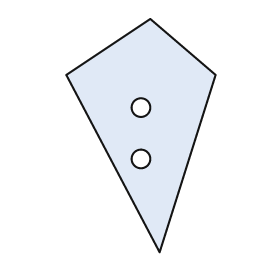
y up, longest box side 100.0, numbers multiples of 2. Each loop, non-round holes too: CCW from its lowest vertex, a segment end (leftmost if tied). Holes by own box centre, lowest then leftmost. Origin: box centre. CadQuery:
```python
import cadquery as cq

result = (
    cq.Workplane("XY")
    .moveTo(8.0, -50.0)
    .lineTo(32.0, 26.0)
    .lineTo(4.0, 50.0)
    .lineTo(-32.0, 26.0)
    .close()
    .moveTo(0.0, -10.0)
    .circle(4.0)
    .moveTo(0.0, 12.0)
    .circle(4.0)
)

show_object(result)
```